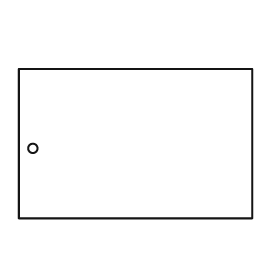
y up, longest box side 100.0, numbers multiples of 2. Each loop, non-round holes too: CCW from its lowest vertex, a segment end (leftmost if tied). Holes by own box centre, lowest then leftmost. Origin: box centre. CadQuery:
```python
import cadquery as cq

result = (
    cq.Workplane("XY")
    .moveTo(-50.0, -32.0)
    .lineTo(50.0, -32.0)
    .lineTo(50.0, 32.0)
    .lineTo(-50.0, 32.0)
    .close()
    .moveTo(-44.0, -2.0)
    .circle(2.0)
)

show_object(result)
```